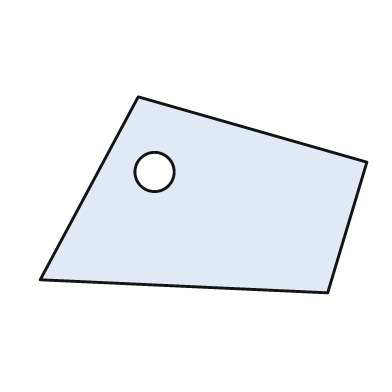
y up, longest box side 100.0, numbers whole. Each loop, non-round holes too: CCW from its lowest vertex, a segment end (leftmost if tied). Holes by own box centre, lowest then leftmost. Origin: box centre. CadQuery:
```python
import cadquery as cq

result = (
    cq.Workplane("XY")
    .moveTo(38.0, -30.0)
    .lineTo(50.0, 10.0)
    .lineTo(-20.0, 30.0)
    .lineTo(-50.0, -26.0)
    .close()
    .moveTo(-15.0, 7.0)
    .circle(6.0)
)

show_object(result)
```